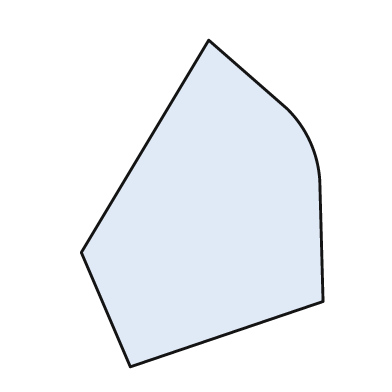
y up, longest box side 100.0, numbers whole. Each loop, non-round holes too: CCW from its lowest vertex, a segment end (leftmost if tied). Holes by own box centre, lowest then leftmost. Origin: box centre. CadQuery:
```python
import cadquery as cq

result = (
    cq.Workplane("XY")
    .moveTo(-22.0, -50.0)
    .lineTo(37.0, -30.0)
    .lineTo(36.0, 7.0)
    .threePointArc((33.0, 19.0), (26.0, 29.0))
    .lineTo(2.0, 50.0)
    .lineTo(-37.0, -15.0)
    .close()
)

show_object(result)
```